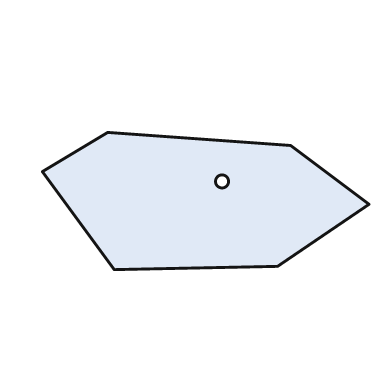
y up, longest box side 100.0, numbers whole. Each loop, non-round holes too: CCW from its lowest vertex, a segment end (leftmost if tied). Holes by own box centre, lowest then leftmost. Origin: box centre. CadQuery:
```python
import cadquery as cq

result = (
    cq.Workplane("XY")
    .moveTo(-28.0, -21.0)
    .lineTo(22.0, -20.0)
    .lineTo(50.0, -1.0)
    .lineTo(26.0, 17.0)
    .lineTo(-30.0, 21.0)
    .lineTo(-50.0, 9.0)
    .close()
    .moveTo(5.0, 6.0)
    .circle(2.0)
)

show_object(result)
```